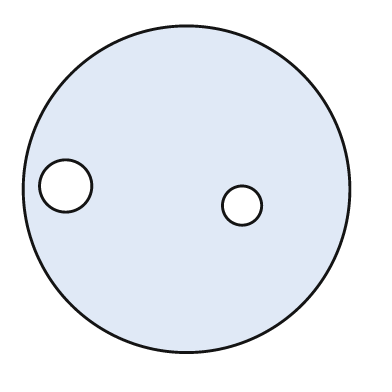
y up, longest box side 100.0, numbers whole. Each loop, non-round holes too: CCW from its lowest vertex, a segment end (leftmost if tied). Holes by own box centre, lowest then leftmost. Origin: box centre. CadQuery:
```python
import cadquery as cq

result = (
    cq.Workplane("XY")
    .moveTo(0.0, 0.0)
    .circle(50.0)
    .moveTo(17.0, -5.0)
    .circle(6.0)
    .moveTo(-37.0, 1.0)
    .circle(8.0)
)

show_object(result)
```